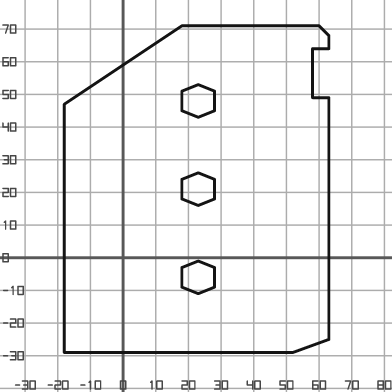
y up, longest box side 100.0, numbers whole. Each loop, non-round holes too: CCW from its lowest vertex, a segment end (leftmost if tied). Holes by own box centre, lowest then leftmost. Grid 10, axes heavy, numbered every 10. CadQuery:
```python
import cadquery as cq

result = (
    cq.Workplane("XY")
    .moveTo(-18.0, -29.0)
    .lineTo(52.0, -29.0)
    .lineTo(63.0, -25.0)
    .lineTo(63.0, 49.0)
    .lineTo(58.0, 49.0)
    .lineTo(58.0, 64.0)
    .lineTo(63.0, 64.0)
    .lineTo(63.0, 68.0)
    .lineTo(60.0, 71.0)
    .lineTo(18.0, 71.0)
    .lineTo(-18.0, 47.0)
    .close()
    .moveTo(23.0, -11.0)
    .lineTo(28.0, -9.0)
    .lineTo(28.0, -3.0)
    .lineTo(23.0, -1.0)
    .lineTo(18.0, -3.0)
    .lineTo(18.0, -9.0)
    .close()
    .moveTo(23.0, 16.0)
    .lineTo(28.0, 18.0)
    .lineTo(28.0, 24.0)
    .lineTo(23.0, 26.0)
    .lineTo(18.0, 24.0)
    .lineTo(18.0, 18.0)
    .close()
    .moveTo(23.0, 43.0)
    .lineTo(28.0, 45.0)
    .lineTo(28.0, 51.0)
    .lineTo(23.0, 53.0)
    .lineTo(18.0, 51.0)
    .lineTo(18.0, 45.0)
    .close()
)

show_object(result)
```